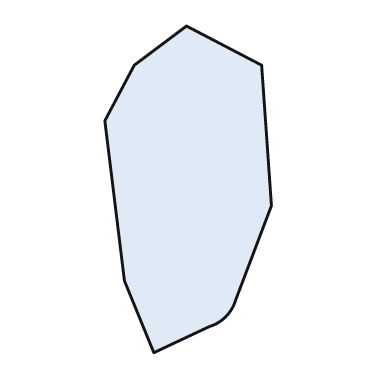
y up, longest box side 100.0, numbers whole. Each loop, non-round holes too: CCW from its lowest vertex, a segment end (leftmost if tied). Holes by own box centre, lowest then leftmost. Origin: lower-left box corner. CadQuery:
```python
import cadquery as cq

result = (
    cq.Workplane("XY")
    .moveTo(15.0, 0.0)
    .lineTo(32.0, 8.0)
    .threePointArc((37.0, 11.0), (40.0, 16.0))
    .lineTo(51.0, 45.0)
    .lineTo(48.0, 88.0)
    .lineTo(25.0, 100.0)
    .lineTo(9.0, 88.0)
    .lineTo(0.0, 71.0)
    .lineTo(6.0, 22.0)
    .close()
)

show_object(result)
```